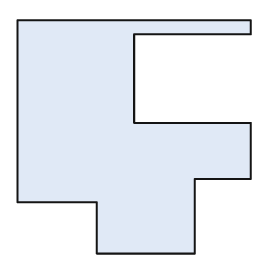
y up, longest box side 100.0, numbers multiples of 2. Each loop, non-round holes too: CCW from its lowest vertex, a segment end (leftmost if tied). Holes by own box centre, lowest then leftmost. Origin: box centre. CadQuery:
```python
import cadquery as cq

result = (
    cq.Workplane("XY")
    .moveTo(-16.0, -50.0)
    .lineTo(26.0, -50.0)
    .lineTo(26.0, -18.0)
    .lineTo(50.0, -18.0)
    .lineTo(50.0, 6.0)
    .lineTo(0.0, 6.0)
    .lineTo(0.0, 44.0)
    .lineTo(50.0, 44.0)
    .lineTo(50.0, 50.0)
    .lineTo(-50.0, 50.0)
    .lineTo(-50.0, -28.0)
    .lineTo(-16.0, -28.0)
    .close()
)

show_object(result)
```